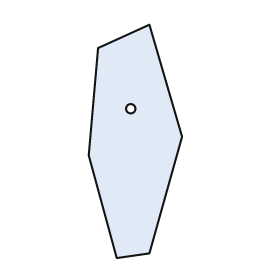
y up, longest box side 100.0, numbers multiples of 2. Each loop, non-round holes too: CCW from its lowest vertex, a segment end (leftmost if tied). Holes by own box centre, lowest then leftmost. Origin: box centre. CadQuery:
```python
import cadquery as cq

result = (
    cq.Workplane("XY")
    .moveTo(-8.0, -50.0)
    .lineTo(6.0, -48.0)
    .lineTo(20.0, 2.0)
    .lineTo(6.0, 50.0)
    .lineTo(-16.0, 40.0)
    .lineTo(-20.0, -6.0)
    .close()
    .moveTo(-2.0, 14.0)
    .circle(2.0)
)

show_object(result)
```